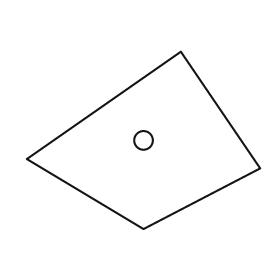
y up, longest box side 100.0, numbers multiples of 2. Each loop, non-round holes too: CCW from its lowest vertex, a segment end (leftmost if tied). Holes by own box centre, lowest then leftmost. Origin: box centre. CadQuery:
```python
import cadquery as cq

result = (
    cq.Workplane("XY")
    .moveTo(0.0, -38.0)
    .lineTo(50.0, -12.0)
    .lineTo(16.0, 38.0)
    .lineTo(-50.0, -8.0)
    .close()
    .moveTo(0.0, 0.0)
    .circle(4.0)
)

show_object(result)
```